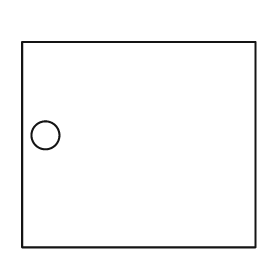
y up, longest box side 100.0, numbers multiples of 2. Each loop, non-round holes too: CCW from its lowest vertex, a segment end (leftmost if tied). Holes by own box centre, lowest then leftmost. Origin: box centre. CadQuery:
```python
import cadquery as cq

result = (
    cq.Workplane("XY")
    .moveTo(-50.0, -44.0)
    .lineTo(50.0, -44.0)
    .lineTo(50.0, 44.0)
    .lineTo(-50.0, 44.0)
    .close()
    .moveTo(-40.0, 4.0)
    .circle(6.0)
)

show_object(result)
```